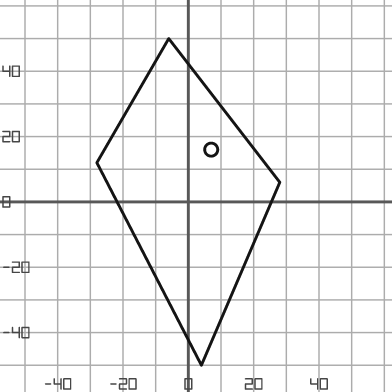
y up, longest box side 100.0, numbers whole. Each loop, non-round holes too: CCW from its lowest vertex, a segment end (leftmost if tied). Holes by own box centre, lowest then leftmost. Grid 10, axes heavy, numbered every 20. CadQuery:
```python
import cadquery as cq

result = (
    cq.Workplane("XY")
    .moveTo(4.0, -50.0)
    .lineTo(28.0, 6.0)
    .lineTo(-6.0, 50.0)
    .lineTo(-28.0, 12.0)
    .close()
    .moveTo(7.0, 16.0)
    .circle(2.0)
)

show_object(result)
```